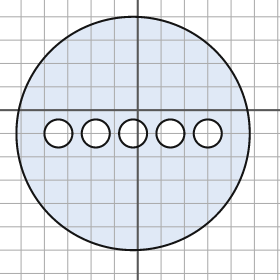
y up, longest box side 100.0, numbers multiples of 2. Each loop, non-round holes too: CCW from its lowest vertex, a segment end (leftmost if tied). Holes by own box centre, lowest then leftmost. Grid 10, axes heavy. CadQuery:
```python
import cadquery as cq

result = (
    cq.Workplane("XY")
    .moveTo(-2.0, -10.0)
    .circle(50.0)
    .moveTo(-34.0, -10.0)
    .circle(6.0)
    .moveTo(-18.0, -10.0)
    .circle(6.0)
    .moveTo(-2.0, -10.0)
    .circle(6.0)
    .moveTo(14.0, -10.0)
    .circle(6.0)
    .moveTo(30.0, -10.0)
    .circle(6.0)
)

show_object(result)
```